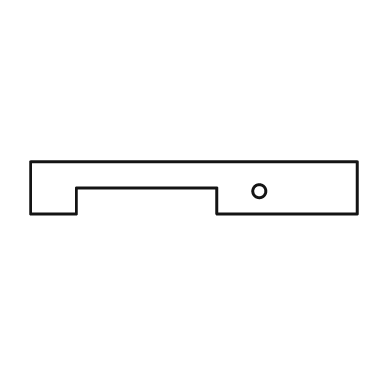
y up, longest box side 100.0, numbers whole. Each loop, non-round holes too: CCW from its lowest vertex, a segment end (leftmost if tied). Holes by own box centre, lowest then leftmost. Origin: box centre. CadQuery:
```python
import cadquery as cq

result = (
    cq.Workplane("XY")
    .moveTo(-50.0, -8.0)
    .lineTo(-36.0, -8.0)
    .lineTo(-36.0, 0.0)
    .lineTo(7.0, 0.0)
    .lineTo(7.0, -8.0)
    .lineTo(50.0, -8.0)
    .lineTo(50.0, 8.0)
    .lineTo(-50.0, 8.0)
    .close()
    .moveTo(20.0, -1.0)
    .circle(2.0)
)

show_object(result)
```